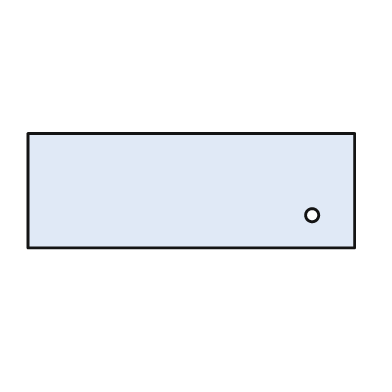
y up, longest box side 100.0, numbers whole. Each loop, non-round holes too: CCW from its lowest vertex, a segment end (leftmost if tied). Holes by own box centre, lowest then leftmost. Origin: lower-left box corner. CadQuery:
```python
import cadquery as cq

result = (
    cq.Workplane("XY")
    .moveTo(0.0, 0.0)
    .lineTo(100.0, 0.0)
    .lineTo(100.0, 35.0)
    .lineTo(0.0, 35.0)
    .close()
    .moveTo(87.0, 10.0)
    .circle(2.0)
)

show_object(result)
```